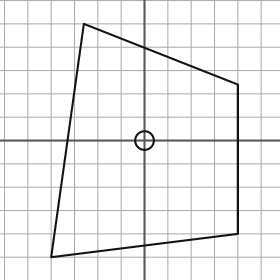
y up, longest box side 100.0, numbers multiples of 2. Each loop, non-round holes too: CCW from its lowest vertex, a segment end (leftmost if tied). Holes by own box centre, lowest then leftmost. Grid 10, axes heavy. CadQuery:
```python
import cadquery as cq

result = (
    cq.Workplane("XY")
    .moveTo(-40.0, -50.0)
    .lineTo(40.0, -40.0)
    .lineTo(40.0, 24.0)
    .lineTo(-26.0, 50.0)
    .close()
    .moveTo(0.0, 0.0)
    .circle(4.0)
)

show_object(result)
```